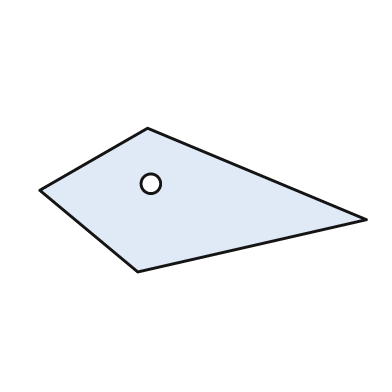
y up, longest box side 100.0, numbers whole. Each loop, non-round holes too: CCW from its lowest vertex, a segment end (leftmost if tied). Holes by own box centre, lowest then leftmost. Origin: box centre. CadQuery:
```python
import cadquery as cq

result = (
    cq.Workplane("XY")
    .moveTo(-20.0, -22.0)
    .lineTo(50.0, -6.0)
    .lineTo(-17.0, 22.0)
    .lineTo(-50.0, 3.0)
    .close()
    .moveTo(-16.0, 5.0)
    .circle(3.0)
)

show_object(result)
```